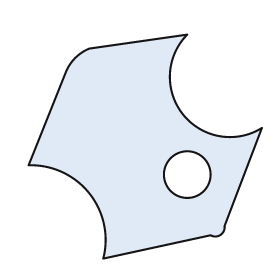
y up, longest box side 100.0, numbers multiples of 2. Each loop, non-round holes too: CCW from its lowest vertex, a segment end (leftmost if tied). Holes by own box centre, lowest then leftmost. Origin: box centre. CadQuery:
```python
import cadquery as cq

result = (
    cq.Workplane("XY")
    .moveTo(-18.0, -48.0)
    .lineTo(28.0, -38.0)
    .threePointArc((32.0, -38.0), (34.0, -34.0))
    .lineTo(50.0, 8.0)
    .threePointArc((16.0, 14.0), (18.0, 48.0))
    .lineTo(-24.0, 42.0)
    .threePointArc((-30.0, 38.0), (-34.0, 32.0))
    .lineTo(-50.0, -8.0)
    .threePointArc((-24.0, -20.0), (-18.0, -48.0))
    .close()
    .moveTo(18.0, -12.0)
    .circle(10.0)
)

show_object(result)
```